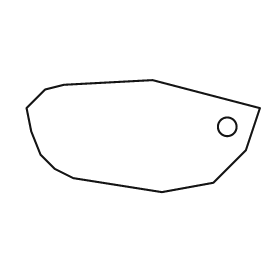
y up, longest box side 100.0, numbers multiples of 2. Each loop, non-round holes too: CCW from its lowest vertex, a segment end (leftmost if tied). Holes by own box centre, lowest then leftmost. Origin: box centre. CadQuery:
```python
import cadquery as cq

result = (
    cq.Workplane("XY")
    .moveTo(8.0, -24.0)
    .lineTo(30.0, -20.0)
    .lineTo(44.0, -6.0)
    .lineTo(50.0, 12.0)
    .lineTo(4.0, 24.0)
    .lineTo(-34.0, 22.0)
    .lineTo(-42.0, 20.0)
    .lineTo(-50.0, 12.0)
    .lineTo(-48.0, 2.0)
    .lineTo(-44.0, -8.0)
    .lineTo(-38.0, -14.0)
    .lineTo(-30.0, -18.0)
    .close()
    .moveTo(36.0, 4.0)
    .circle(4.0)
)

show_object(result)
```